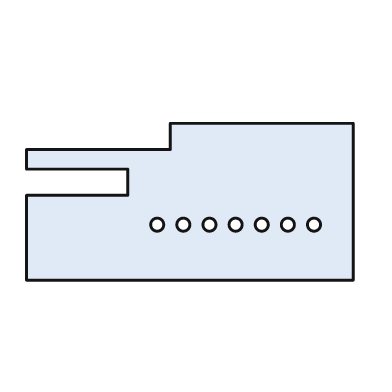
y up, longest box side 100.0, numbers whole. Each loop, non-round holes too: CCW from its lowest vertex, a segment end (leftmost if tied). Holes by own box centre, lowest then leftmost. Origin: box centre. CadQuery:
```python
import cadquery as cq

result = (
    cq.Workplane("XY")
    .moveTo(-50.0, -24.0)
    .lineTo(50.0, -24.0)
    .lineTo(50.0, 24.0)
    .lineTo(-6.0, 24.0)
    .lineTo(-6.0, 16.0)
    .lineTo(-50.0, 16.0)
    .lineTo(-50.0, 10.0)
    .lineTo(-19.0, 10.0)
    .lineTo(-19.0, 2.0)
    .lineTo(-50.0, 2.0)
    .close()
    .moveTo(-10.0, -7.0)
    .circle(2.0)
    .moveTo(-2.0, -7.0)
    .circle(2.0)
    .moveTo(6.0, -7.0)
    .circle(2.0)
    .moveTo(14.0, -7.0)
    .circle(2.0)
    .moveTo(22.0, -7.0)
    .circle(2.0)
    .moveTo(30.0, -7.0)
    .circle(2.0)
    .moveTo(38.0, -7.0)
    .circle(2.0)
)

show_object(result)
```